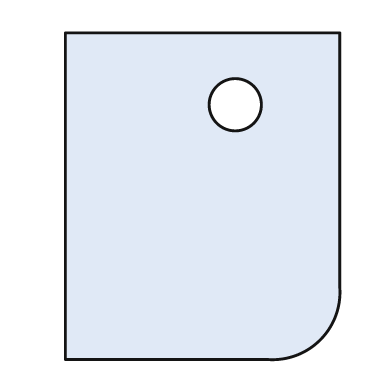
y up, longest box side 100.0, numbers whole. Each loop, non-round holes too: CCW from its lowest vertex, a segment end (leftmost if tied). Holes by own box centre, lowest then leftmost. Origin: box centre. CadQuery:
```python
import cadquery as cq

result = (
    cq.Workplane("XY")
    .moveTo(-42.0, -50.0)
    .lineTo(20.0, -50.0)
    .threePointArc((36.0, -44.0), (42.0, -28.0))
    .lineTo(42.0, 50.0)
    .lineTo(-42.0, 50.0)
    .close()
    .moveTo(10.0, 28.0)
    .circle(8.0)
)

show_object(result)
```